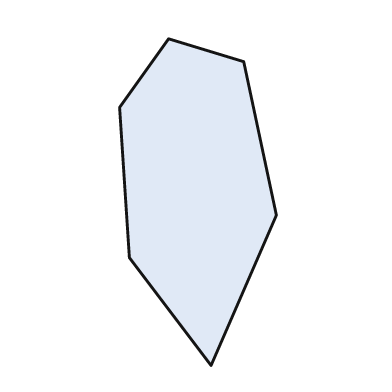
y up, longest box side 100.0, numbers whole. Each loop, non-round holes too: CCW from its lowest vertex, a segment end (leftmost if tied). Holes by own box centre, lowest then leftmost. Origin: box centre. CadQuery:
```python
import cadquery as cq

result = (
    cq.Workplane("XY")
    .moveTo(4.0, -50.0)
    .lineTo(24.0, -4.0)
    .lineTo(14.0, 43.0)
    .lineTo(-9.0, 50.0)
    .lineTo(-24.0, 29.0)
    .lineTo(-21.0, -17.0)
    .close()
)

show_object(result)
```